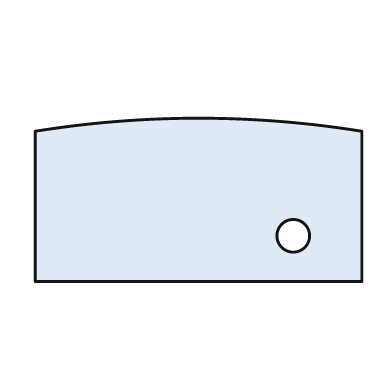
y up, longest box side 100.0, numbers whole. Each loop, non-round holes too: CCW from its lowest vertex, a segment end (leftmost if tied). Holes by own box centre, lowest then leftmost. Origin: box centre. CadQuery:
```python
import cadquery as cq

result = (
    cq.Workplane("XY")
    .moveTo(-50.0, -25.0)
    .lineTo(50.0, -25.0)
    .lineTo(50.0, 21.0)
    .threePointArc((0.0, 25.0), (-50.0, 21.0))
    .close()
    .moveTo(29.0, -11.0)
    .circle(5.0)
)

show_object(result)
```